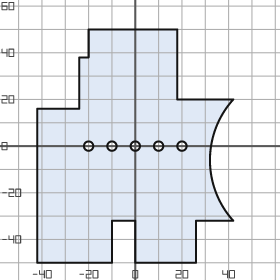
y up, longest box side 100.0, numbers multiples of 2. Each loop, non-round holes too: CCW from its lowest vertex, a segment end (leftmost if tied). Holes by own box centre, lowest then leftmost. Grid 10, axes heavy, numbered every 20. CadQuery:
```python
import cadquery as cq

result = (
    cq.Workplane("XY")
    .moveTo(-42.0, -50.0)
    .lineTo(-10.0, -50.0)
    .lineTo(-10.0, -32.0)
    .lineTo(0.0, -32.0)
    .lineTo(0.0, -50.0)
    .lineTo(26.0, -50.0)
    .lineTo(26.0, -32.0)
    .lineTo(42.0, -32.0)
    .threePointArc((32.0, -6.0), (42.0, 20.0))
    .lineTo(18.0, 20.0)
    .lineTo(18.0, 50.0)
    .lineTo(-20.0, 50.0)
    .lineTo(-20.0, 38.0)
    .lineTo(-24.0, 38.0)
    .lineTo(-24.0, 16.0)
    .lineTo(-42.0, 16.0)
    .close()
    .moveTo(-20.0, 0.0)
    .circle(2.0)
    .moveTo(-10.0, 0.0)
    .circle(2.0)
    .moveTo(0.0, 0.0)
    .circle(2.0)
    .moveTo(10.0, 0.0)
    .circle(2.0)
    .moveTo(20.0, 0.0)
    .circle(2.0)
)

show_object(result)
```